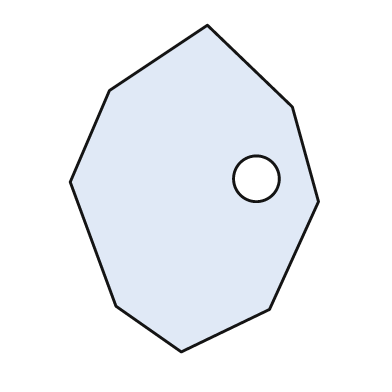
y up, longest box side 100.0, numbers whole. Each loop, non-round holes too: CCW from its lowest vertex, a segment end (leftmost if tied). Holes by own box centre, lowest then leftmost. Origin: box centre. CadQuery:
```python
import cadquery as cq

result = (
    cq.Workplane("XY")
    .moveTo(-4.0, -50.0)
    .lineTo(23.0, -37.0)
    .lineTo(38.0, -4.0)
    .lineTo(30.0, 25.0)
    .lineTo(4.0, 50.0)
    .lineTo(-26.0, 30.0)
    .lineTo(-38.0, 2.0)
    .lineTo(-24.0, -36.0)
    .close()
    .moveTo(19.0, 3.0)
    .circle(7.0)
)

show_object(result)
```